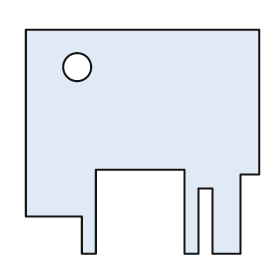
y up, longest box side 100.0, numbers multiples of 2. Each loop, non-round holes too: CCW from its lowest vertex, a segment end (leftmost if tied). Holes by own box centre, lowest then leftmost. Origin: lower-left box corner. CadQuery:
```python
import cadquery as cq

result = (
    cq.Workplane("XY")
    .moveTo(24.0, 0.0)
    .lineTo(30.0, 0.0)
    .lineTo(30.0, 36.0)
    .lineTo(68.0, 36.0)
    .lineTo(68.0, 0.0)
    .lineTo(74.0, 0.0)
    .lineTo(74.0, 28.0)
    .lineTo(80.0, 28.0)
    .lineTo(80.0, 0.0)
    .lineTo(92.0, 0.0)
    .lineTo(92.0, 34.0)
    .lineTo(100.0, 34.0)
    .lineTo(100.0, 96.0)
    .lineTo(0.0, 96.0)
    .lineTo(0.0, 16.0)
    .lineTo(24.0, 16.0)
    .close()
    .moveTo(22.0, 80.0)
    .circle(6.0)
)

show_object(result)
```